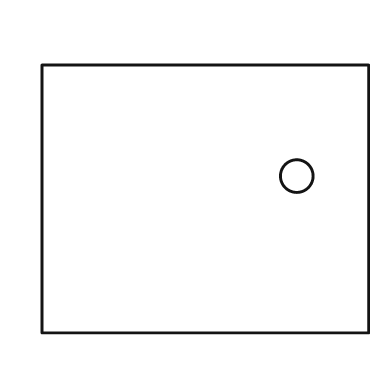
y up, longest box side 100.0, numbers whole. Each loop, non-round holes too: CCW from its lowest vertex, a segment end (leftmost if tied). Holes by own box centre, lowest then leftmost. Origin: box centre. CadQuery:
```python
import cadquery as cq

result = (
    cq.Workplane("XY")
    .moveTo(-50.0, -41.0)
    .lineTo(50.0, -41.0)
    .lineTo(50.0, 41.0)
    .lineTo(-50.0, 41.0)
    .close()
    .moveTo(28.0, 7.0)
    .circle(5.0)
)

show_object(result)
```